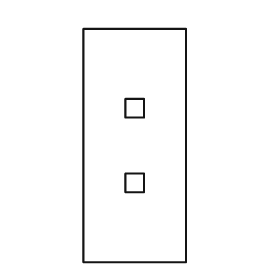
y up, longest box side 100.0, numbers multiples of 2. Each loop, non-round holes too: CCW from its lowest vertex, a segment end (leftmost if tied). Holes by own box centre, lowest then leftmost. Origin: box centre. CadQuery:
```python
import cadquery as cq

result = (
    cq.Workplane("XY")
    .moveTo(-22.0, -50.0)
    .lineTo(22.0, -50.0)
    .lineTo(22.0, 50.0)
    .lineTo(-22.0, 50.0)
    .close()
    .moveTo(-4.0, -20.0)
    .lineTo(4.0, -20.0)
    .lineTo(4.0, -12.0)
    .lineTo(-4.0, -12.0)
    .close()
    .moveTo(-4.0, 12.0)
    .lineTo(4.0, 12.0)
    .lineTo(4.0, 20.0)
    .lineTo(-4.0, 20.0)
    .close()
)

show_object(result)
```